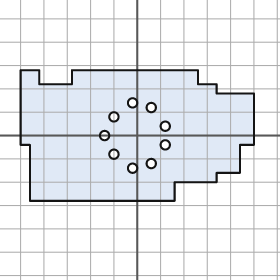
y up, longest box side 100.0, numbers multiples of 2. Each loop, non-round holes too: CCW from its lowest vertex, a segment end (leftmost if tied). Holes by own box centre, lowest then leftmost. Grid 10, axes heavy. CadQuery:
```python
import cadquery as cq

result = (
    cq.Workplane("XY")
    .moveTo(-46.0, -28.0)
    .lineTo(16.0, -28.0)
    .lineTo(16.0, -20.0)
    .lineTo(34.0, -20.0)
    .lineTo(34.0, -16.0)
    .lineTo(44.0, -16.0)
    .lineTo(44.0, -4.0)
    .lineTo(50.0, -4.0)
    .lineTo(50.0, 18.0)
    .lineTo(34.0, 18.0)
    .lineTo(34.0, 22.0)
    .lineTo(26.0, 22.0)
    .lineTo(26.0, 28.0)
    .lineTo(-28.0, 28.0)
    .lineTo(-28.0, 22.0)
    .lineTo(-42.0, 22.0)
    .lineTo(-42.0, 28.0)
    .lineTo(-50.0, 28.0)
    .lineTo(-50.0, -4.0)
    .lineTo(-46.0, -4.0)
    .close()
    .moveTo(-2.0, -14.0)
    .circle(2.0)
    .moveTo(6.0, -12.0)
    .circle(2.0)
    .moveTo(-10.0, -8.0)
    .circle(2.0)
    .moveTo(12.0, -4.0)
    .circle(2.0)
    .moveTo(-14.0, 0.0)
    .circle(2.0)
    .moveTo(12.0, 4.0)
    .circle(2.0)
    .moveTo(-10.0, 8.0)
    .circle(2.0)
    .moveTo(6.0, 12.0)
    .circle(2.0)
    .moveTo(-2.0, 14.0)
    .circle(2.0)
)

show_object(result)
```